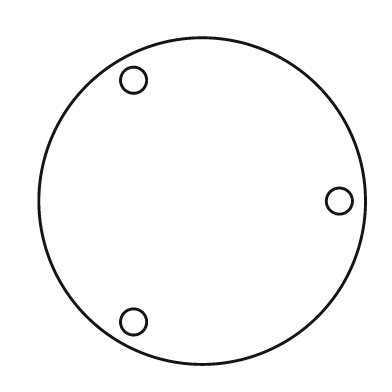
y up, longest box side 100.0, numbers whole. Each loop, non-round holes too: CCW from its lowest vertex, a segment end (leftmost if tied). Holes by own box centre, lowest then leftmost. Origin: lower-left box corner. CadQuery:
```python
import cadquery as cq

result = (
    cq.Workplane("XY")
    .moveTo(50.0, 50.0)
    .circle(50.0)
    .moveTo(29.0, 13.0)
    .circle(4.0)
    .moveTo(92.0, 50.0)
    .circle(4.0)
    .moveTo(29.0, 87.0)
    .circle(4.0)
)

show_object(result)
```